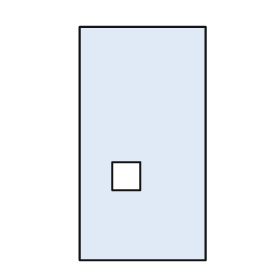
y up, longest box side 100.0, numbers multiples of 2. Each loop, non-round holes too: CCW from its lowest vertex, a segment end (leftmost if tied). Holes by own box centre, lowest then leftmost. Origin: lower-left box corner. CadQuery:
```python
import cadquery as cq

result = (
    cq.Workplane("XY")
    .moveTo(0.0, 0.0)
    .lineTo(54.0, 0.0)
    .lineTo(54.0, 100.0)
    .lineTo(0.0, 100.0)
    .close()
    .moveTo(14.0, 30.0)
    .lineTo(26.0, 30.0)
    .lineTo(26.0, 42.0)
    .lineTo(14.0, 42.0)
    .close()
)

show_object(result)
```